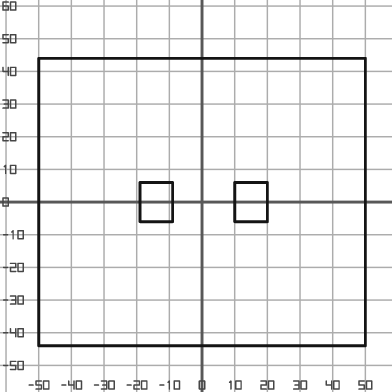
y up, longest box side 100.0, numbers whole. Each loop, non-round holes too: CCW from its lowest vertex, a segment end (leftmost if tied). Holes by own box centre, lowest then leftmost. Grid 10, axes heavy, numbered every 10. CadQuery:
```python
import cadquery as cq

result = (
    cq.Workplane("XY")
    .moveTo(-50.0, -44.0)
    .lineTo(50.0, -44.0)
    .lineTo(50.0, 44.0)
    .lineTo(-50.0, 44.0)
    .close()
    .moveTo(-19.0, -6.0)
    .lineTo(-9.0, -6.0)
    .lineTo(-9.0, 6.0)
    .lineTo(-19.0, 6.0)
    .close()
    .moveTo(10.0, -6.0)
    .lineTo(20.0, -6.0)
    .lineTo(20.0, 6.0)
    .lineTo(10.0, 6.0)
    .close()
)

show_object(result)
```